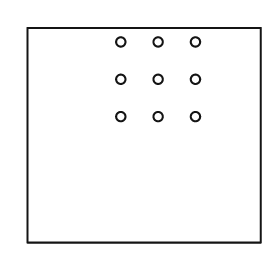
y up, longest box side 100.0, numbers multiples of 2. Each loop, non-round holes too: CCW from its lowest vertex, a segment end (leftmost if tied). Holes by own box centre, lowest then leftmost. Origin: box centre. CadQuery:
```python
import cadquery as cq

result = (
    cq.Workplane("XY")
    .moveTo(-50.0, -46.0)
    .lineTo(50.0, -46.0)
    .lineTo(50.0, 46.0)
    .lineTo(-50.0, 46.0)
    .close()
    .moveTo(-10.0, 8.0)
    .circle(2.0)
    .moveTo(6.0, 8.0)
    .circle(2.0)
    .moveTo(22.0, 8.0)
    .circle(2.0)
    .moveTo(-10.0, 24.0)
    .circle(2.0)
    .moveTo(6.0, 24.0)
    .circle(2.0)
    .moveTo(22.0, 24.0)
    .circle(2.0)
    .moveTo(-10.0, 40.0)
    .circle(2.0)
    .moveTo(6.0, 40.0)
    .circle(2.0)
    .moveTo(22.0, 40.0)
    .circle(2.0)
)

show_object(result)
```